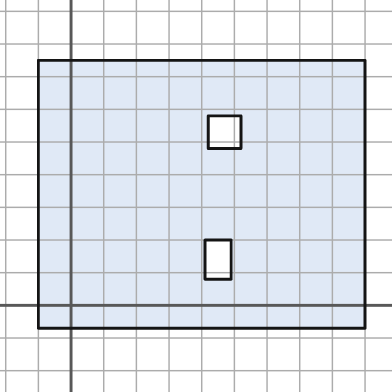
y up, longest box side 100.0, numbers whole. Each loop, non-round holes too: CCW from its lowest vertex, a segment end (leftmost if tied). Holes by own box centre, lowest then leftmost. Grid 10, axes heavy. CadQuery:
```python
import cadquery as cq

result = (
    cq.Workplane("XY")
    .moveTo(-10.0, -7.0)
    .lineTo(90.0, -7.0)
    .lineTo(90.0, 75.0)
    .lineTo(-10.0, 75.0)
    .close()
    .moveTo(41.0, 8.0)
    .lineTo(49.0, 8.0)
    .lineTo(49.0, 20.0)
    .lineTo(41.0, 20.0)
    .close()
    .moveTo(42.0, 48.0)
    .lineTo(52.0, 48.0)
    .lineTo(52.0, 58.0)
    .lineTo(42.0, 58.0)
    .close()
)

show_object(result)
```